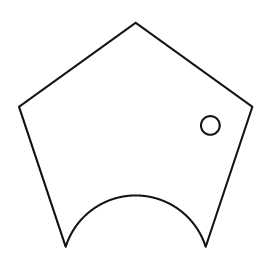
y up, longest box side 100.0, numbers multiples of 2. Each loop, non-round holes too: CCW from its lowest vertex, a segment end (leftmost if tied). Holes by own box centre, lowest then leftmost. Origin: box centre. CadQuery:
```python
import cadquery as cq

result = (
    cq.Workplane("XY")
    .moveTo(-30.0, -48.0)
    .threePointArc((0.0, -26.0), (30.0, -48.0))
    .lineTo(50.0, 12.0)
    .lineTo(0.0, 48.0)
    .lineTo(-50.0, 12.0)
    .close()
    .moveTo(32.0, 4.0)
    .circle(4.0)
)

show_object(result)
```